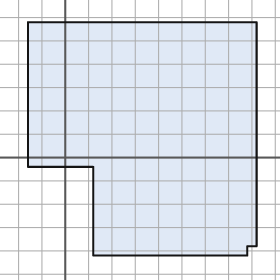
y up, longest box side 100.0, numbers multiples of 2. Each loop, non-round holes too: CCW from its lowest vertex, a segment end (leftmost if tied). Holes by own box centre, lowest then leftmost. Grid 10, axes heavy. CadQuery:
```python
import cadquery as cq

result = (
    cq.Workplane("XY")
    .moveTo(12.0, -42.0)
    .lineTo(78.0, -42.0)
    .lineTo(78.0, -38.0)
    .lineTo(82.0, -38.0)
    .lineTo(82.0, 58.0)
    .lineTo(-16.0, 58.0)
    .lineTo(-16.0, -4.0)
    .lineTo(12.0, -4.0)
    .close()
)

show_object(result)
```